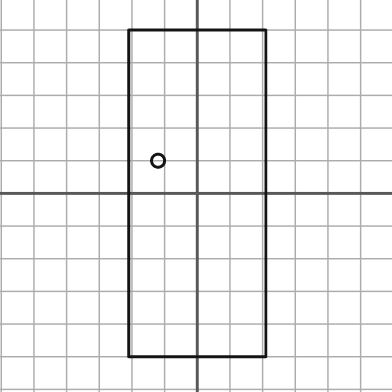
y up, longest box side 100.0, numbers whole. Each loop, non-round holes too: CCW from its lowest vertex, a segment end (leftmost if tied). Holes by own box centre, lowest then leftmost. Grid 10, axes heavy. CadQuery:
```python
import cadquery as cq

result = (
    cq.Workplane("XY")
    .moveTo(-21.0, -50.0)
    .lineTo(21.0, -50.0)
    .lineTo(21.0, 50.0)
    .lineTo(-21.0, 50.0)
    .close()
    .moveTo(-12.0, 10.0)
    .circle(2.0)
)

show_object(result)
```